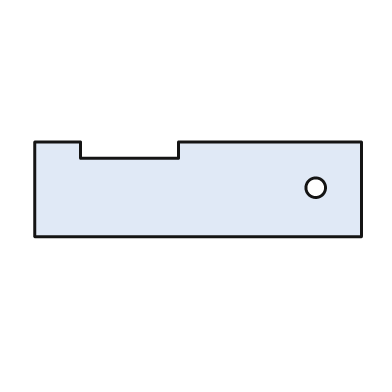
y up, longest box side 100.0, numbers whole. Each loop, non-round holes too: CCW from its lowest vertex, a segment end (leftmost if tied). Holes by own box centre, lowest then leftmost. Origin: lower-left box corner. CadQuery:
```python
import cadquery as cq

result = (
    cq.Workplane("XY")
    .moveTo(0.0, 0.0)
    .lineTo(100.0, 0.0)
    .lineTo(100.0, 29.0)
    .lineTo(44.0, 29.0)
    .lineTo(44.0, 24.0)
    .lineTo(14.0, 24.0)
    .lineTo(14.0, 29.0)
    .lineTo(0.0, 29.0)
    .close()
    .moveTo(86.0, 15.0)
    .circle(3.0)
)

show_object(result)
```